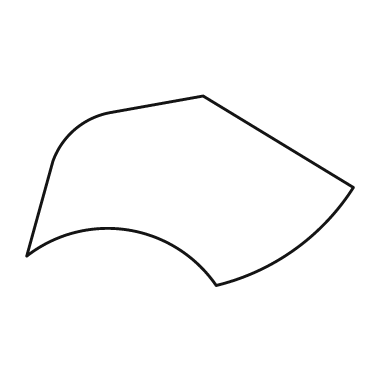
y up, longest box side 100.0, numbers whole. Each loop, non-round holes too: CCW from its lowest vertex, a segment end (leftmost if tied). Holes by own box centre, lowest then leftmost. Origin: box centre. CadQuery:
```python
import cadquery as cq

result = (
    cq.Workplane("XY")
    .moveTo(8.0, -29.0)
    .threePointArc((32.0, -18.0), (50.0, 1.0))
    .lineTo(4.0, 29.0)
    .lineTo(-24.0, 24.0)
    .threePointArc((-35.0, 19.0), (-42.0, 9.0))
    .lineTo(-50.0, -20.0)
    .threePointArc((-19.0, -12.0), (8.0, -29.0))
    .close()
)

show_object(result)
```